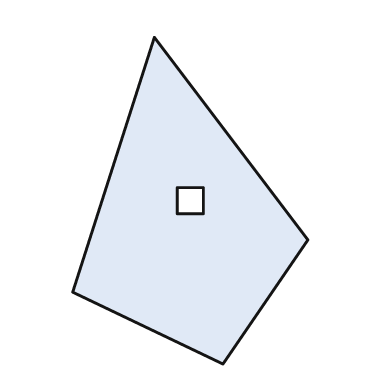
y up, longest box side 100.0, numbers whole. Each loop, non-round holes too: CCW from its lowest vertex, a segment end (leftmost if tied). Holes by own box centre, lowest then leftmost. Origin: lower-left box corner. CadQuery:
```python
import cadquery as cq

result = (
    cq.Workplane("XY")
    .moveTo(46.0, 0.0)
    .lineTo(72.0, 38.0)
    .lineTo(25.0, 100.0)
    .lineTo(0.0, 22.0)
    .close()
    .moveTo(32.0, 46.0)
    .lineTo(40.0, 46.0)
    .lineTo(40.0, 54.0)
    .lineTo(32.0, 54.0)
    .close()
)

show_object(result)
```